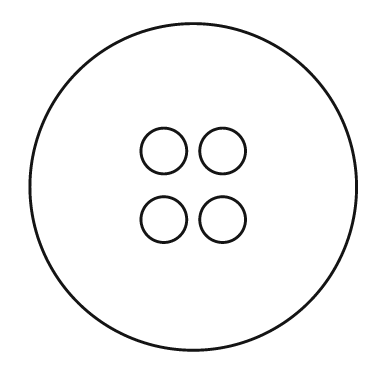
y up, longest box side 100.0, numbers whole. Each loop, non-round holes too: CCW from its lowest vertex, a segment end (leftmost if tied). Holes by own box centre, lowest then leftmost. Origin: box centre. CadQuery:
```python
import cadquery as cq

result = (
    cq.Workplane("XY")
    .moveTo(0.0, 0.0)
    .circle(50.0)
    .moveTo(-9.0, -10.0)
    .circle(7.0)
    .moveTo(9.0, -10.0)
    .circle(7.0)
    .moveTo(-9.0, 11.0)
    .circle(7.0)
    .moveTo(9.0, 11.0)
    .circle(7.0)
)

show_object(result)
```